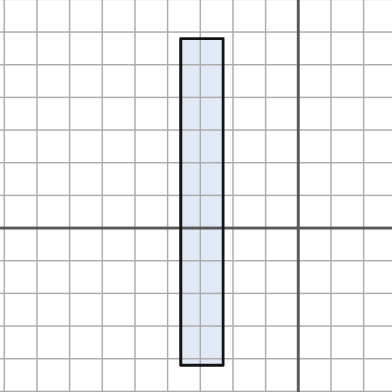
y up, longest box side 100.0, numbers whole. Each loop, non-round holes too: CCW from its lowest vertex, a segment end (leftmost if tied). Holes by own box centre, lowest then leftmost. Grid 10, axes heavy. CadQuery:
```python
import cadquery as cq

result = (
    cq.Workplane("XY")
    .moveTo(-36.0, -42.0)
    .lineTo(-23.0, -42.0)
    .lineTo(-23.0, 58.0)
    .lineTo(-36.0, 58.0)
    .close()
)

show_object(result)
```